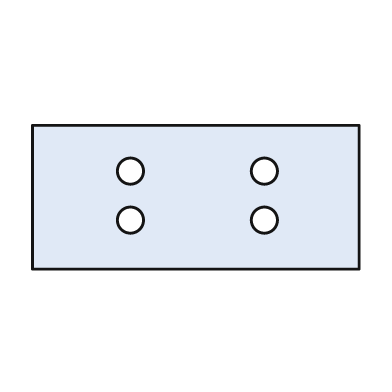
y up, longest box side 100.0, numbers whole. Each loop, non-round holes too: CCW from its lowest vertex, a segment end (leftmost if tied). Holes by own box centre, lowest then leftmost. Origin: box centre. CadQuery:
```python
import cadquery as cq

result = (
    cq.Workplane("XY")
    .moveTo(-50.0, -22.0)
    .lineTo(50.0, -22.0)
    .lineTo(50.0, 22.0)
    .lineTo(-50.0, 22.0)
    .close()
    .moveTo(-20.0, -7.0)
    .circle(4.0)
    .moveTo(21.0, -7.0)
    .circle(4.0)
    .moveTo(-20.0, 8.0)
    .circle(4.0)
    .moveTo(21.0, 8.0)
    .circle(4.0)
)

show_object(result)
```